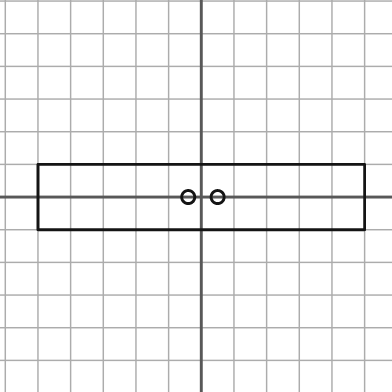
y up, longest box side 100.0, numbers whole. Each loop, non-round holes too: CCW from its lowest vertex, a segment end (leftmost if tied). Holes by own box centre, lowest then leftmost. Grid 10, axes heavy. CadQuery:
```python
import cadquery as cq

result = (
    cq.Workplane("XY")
    .moveTo(-50.0, -10.0)
    .lineTo(50.0, -10.0)
    .lineTo(50.0, 10.0)
    .lineTo(-50.0, 10.0)
    .close()
    .moveTo(-4.0, 0.0)
    .circle(2.0)
    .moveTo(5.0, 0.0)
    .circle(2.0)
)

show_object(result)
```